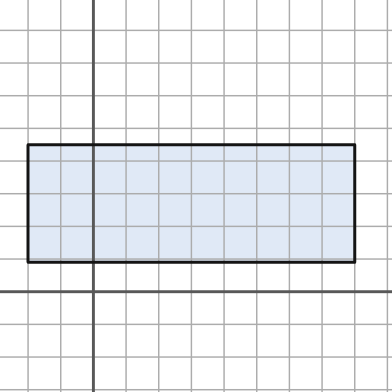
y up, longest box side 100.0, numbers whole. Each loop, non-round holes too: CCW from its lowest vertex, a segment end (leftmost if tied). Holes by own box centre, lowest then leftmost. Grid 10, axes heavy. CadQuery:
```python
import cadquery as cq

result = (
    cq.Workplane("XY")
    .moveTo(-20.0, 9.0)
    .lineTo(80.0, 9.0)
    .lineTo(80.0, 45.0)
    .lineTo(-20.0, 45.0)
    .close()
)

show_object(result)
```